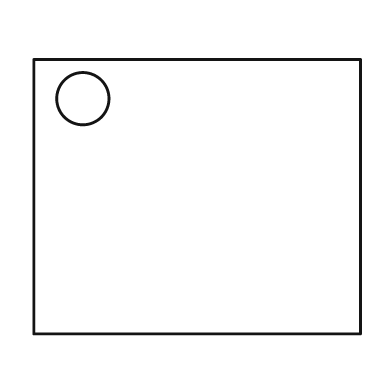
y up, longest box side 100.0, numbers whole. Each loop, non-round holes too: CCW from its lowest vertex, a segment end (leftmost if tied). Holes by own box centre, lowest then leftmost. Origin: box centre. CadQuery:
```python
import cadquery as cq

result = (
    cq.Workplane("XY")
    .moveTo(-50.0, -42.0)
    .lineTo(50.0, -42.0)
    .lineTo(50.0, 42.0)
    .lineTo(-50.0, 42.0)
    .close()
    .moveTo(-35.0, 30.0)
    .circle(8.0)
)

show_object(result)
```